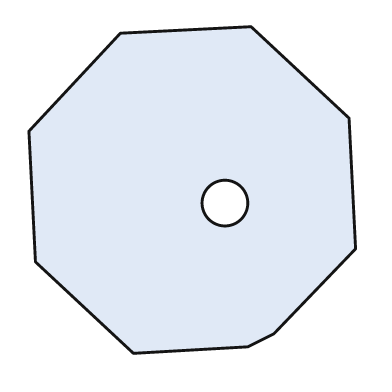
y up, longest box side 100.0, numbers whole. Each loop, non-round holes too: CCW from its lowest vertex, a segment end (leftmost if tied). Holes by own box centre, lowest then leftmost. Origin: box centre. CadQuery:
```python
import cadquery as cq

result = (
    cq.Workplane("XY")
    .moveTo(-18.0, -50.0)
    .lineTo(17.0, -48.0)
    .lineTo(25.0, -44.0)
    .lineTo(50.0, -18.0)
    .lineTo(48.0, 22.0)
    .lineTo(18.0, 50.0)
    .lineTo(-22.0, 48.0)
    .lineTo(-50.0, 18.0)
    .lineTo(-48.0, -22.0)
    .close()
    .moveTo(10.0, -4.0)
    .circle(7.0)
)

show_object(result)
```